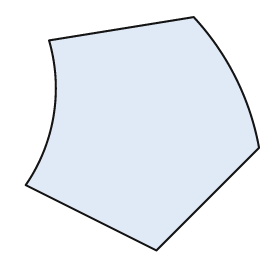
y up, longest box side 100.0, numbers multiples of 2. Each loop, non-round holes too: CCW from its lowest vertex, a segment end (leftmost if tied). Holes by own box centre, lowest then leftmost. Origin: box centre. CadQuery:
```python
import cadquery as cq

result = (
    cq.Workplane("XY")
    .moveTo(6.0, -50.0)
    .lineTo(50.0, -6.0)
    .threePointArc((40.0, 24.0), (22.0, 50.0))
    .lineTo(-40.0, 40.0)
    .threePointArc((-38.0, 8.0), (-50.0, -22.0))
    .close()
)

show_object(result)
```